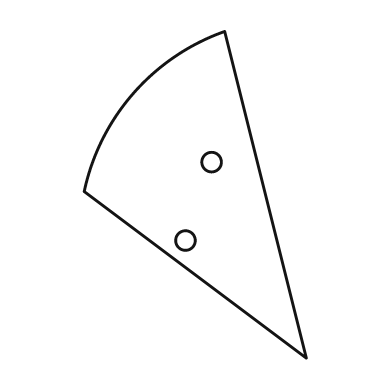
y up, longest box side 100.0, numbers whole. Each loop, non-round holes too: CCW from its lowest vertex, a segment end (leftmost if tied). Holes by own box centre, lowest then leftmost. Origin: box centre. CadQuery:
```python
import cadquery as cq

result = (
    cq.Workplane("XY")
    .moveTo(34.0, -50.0)
    .lineTo(9.0, 50.0)
    .threePointArc((-19.0, 31.0), (-34.0, 1.0))
    .close()
    .moveTo(-3.0, -14.0)
    .circle(3.0)
    .moveTo(5.0, 10.0)
    .circle(3.0)
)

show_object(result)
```